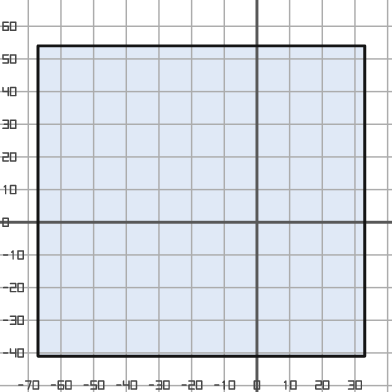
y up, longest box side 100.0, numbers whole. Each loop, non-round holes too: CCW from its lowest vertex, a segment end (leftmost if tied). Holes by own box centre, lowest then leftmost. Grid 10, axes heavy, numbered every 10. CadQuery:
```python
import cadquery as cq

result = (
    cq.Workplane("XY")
    .moveTo(-67.0, -41.0)
    .lineTo(33.0, -41.0)
    .lineTo(33.0, 54.0)
    .lineTo(-67.0, 54.0)
    .close()
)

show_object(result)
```